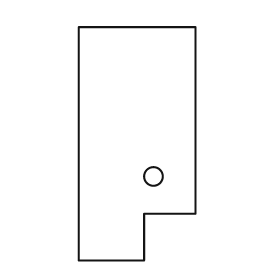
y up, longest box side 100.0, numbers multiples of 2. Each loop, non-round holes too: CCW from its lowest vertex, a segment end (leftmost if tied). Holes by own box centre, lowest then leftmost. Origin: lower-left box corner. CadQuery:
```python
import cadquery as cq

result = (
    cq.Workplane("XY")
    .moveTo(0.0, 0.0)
    .lineTo(28.0, 0.0)
    .lineTo(28.0, 20.0)
    .lineTo(50.0, 20.0)
    .lineTo(50.0, 100.0)
    .lineTo(0.0, 100.0)
    .close()
    .moveTo(32.0, 36.0)
    .circle(4.0)
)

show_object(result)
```